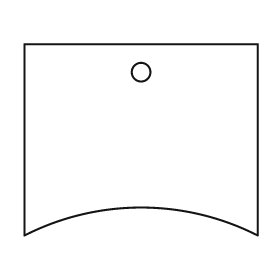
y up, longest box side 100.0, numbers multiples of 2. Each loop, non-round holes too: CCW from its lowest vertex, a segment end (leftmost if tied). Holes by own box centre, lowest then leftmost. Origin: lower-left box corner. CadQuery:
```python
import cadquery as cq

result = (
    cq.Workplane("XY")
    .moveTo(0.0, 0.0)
    .threePointArc((50.0, 12.0), (100.0, 0.0))
    .lineTo(100.0, 82.0)
    .lineTo(0.0, 82.0)
    .close()
    .moveTo(50.0, 70.0)
    .circle(4.0)
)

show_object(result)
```